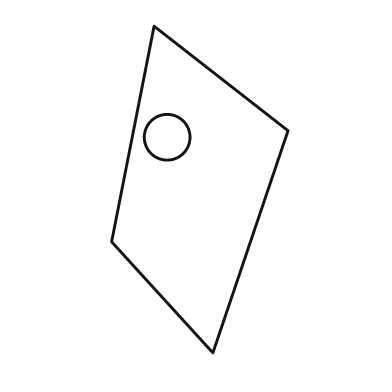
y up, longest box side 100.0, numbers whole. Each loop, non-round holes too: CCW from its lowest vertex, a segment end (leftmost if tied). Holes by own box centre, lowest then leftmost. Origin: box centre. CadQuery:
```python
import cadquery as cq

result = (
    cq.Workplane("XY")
    .moveTo(4.0, -50.0)
    .lineTo(27.0, 18.0)
    .lineTo(-14.0, 50.0)
    .lineTo(-27.0, -16.0)
    .close()
    .moveTo(-10.0, 16.0)
    .circle(7.0)
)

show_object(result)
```